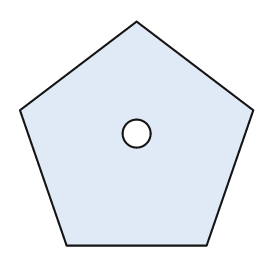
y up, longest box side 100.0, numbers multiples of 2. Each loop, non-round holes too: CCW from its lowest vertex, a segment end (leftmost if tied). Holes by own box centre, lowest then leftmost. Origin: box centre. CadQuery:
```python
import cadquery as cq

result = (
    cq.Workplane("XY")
    .moveTo(-30.0, -48.0)
    .lineTo(30.0, -48.0)
    .lineTo(50.0, 10.0)
    .lineTo(0.0, 48.0)
    .lineTo(-50.0, 10.0)
    .close()
    .moveTo(0.0, 0.0)
    .circle(6.0)
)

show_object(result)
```